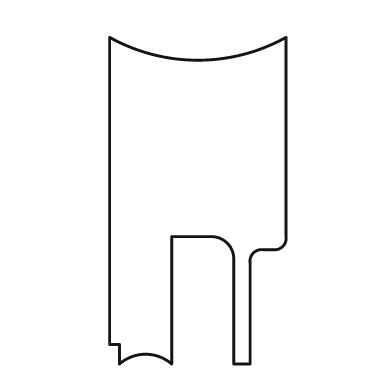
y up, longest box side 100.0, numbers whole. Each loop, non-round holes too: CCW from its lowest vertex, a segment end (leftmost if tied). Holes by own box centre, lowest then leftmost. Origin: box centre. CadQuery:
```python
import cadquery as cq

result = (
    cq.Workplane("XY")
    .moveTo(-24.0, -50.0)
    .threePointArc((-16.0, -47.0), (-8.0, -50.0))
    .lineTo(-8.0, -11.0)
    .lineTo(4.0, -11.0)
    .threePointArc((9.0, -13.0), (11.0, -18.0))
    .lineTo(11.0, -50.0)
    .lineTo(16.0, -50.0)
    .lineTo(16.0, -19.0)
    .threePointArc((17.0, -16.0), (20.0, -15.0))
    .lineTo(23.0, -15.0)
    .threePointArc((26.0, -14.0), (27.0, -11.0))
    .lineTo(27.0, 50.0)
    .threePointArc((0.0, 43.0), (-27.0, 50.0))
    .lineTo(-27.0, -44.0)
    .lineTo(-24.0, -44.0)
    .close()
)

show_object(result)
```